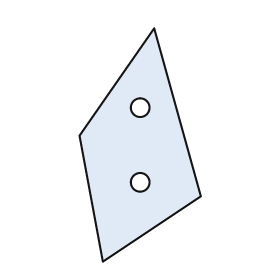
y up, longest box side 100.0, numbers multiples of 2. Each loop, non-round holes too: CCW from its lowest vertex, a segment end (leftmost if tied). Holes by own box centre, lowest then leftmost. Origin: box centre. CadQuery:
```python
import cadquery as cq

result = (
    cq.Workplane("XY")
    .moveTo(-16.0, -50.0)
    .lineTo(26.0, -22.0)
    .lineTo(6.0, 50.0)
    .lineTo(-26.0, 4.0)
    .close()
    .moveTo(0.0, -16.0)
    .circle(4.0)
    .moveTo(0.0, 16.0)
    .circle(4.0)
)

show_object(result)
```